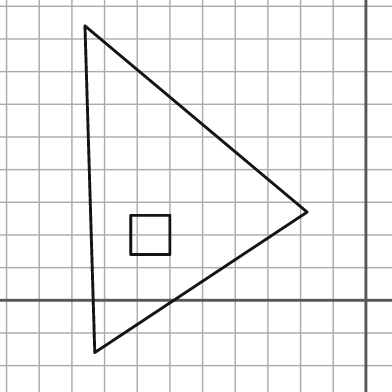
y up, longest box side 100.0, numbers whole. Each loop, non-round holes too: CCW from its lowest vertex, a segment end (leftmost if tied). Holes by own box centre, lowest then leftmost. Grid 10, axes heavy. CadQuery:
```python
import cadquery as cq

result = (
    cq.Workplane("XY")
    .moveTo(-83.0, -16.0)
    .lineTo(-18.0, 27.0)
    .lineTo(-86.0, 84.0)
    .close()
    .moveTo(-72.0, 14.0)
    .lineTo(-60.0, 14.0)
    .lineTo(-60.0, 26.0)
    .lineTo(-72.0, 26.0)
    .close()
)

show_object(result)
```